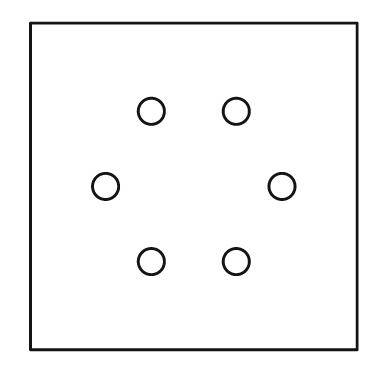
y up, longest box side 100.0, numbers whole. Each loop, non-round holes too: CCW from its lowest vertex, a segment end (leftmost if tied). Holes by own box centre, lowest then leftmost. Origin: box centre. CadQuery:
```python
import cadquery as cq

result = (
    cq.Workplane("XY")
    .moveTo(-50.0, -50.0)
    .lineTo(50.0, -50.0)
    .lineTo(50.0, 50.0)
    .lineTo(-50.0, 50.0)
    .close()
    .moveTo(-13.0, -23.0)
    .circle(4.0)
    .moveTo(13.0, -23.0)
    .circle(4.0)
    .moveTo(-27.0, 0.0)
    .circle(4.0)
    .moveTo(27.0, 0.0)
    .circle(4.0)
    .moveTo(-13.0, 23.0)
    .circle(4.0)
    .moveTo(13.0, 23.0)
    .circle(4.0)
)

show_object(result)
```